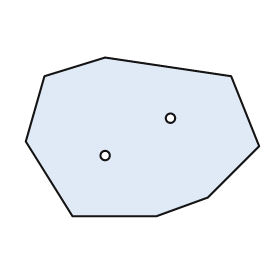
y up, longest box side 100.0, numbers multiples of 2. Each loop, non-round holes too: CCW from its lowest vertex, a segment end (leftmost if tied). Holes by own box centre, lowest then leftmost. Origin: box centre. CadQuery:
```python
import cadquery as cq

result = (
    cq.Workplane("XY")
    .moveTo(-30.0, -34.0)
    .lineTo(6.0, -34.0)
    .lineTo(28.0, -26.0)
    .lineTo(50.0, -4.0)
    .lineTo(38.0, 26.0)
    .lineTo(-16.0, 34.0)
    .lineTo(-42.0, 26.0)
    .lineTo(-50.0, -2.0)
    .close()
    .moveTo(-16.0, -8.0)
    .circle(2.0)
    .moveTo(12.0, 8.0)
    .circle(2.0)
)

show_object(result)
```